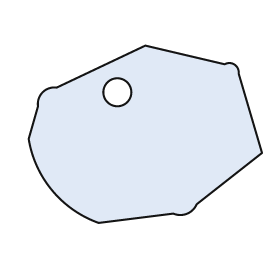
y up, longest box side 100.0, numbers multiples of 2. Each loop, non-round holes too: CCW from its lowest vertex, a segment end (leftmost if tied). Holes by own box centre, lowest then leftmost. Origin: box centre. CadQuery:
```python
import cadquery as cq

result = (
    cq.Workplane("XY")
    .moveTo(-20.0, -38.0)
    .lineTo(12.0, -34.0)
    .threePointArc((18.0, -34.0), (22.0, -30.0))
    .lineTo(50.0, -8.0)
    .lineTo(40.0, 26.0)
    .threePointArc((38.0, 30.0), (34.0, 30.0))
    .lineTo(0.0, 38.0)
    .lineTo(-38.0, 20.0)
    .threePointArc((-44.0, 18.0), (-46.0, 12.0))
    .lineTo(-50.0, -2.0)
    .threePointArc((-40.0, -24.0), (-20.0, -38.0))
    .close()
    .moveTo(-12.0, 18.0)
    .circle(6.0)
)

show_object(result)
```